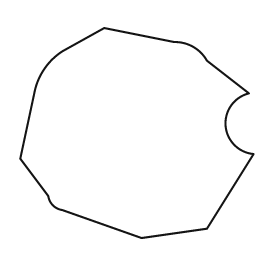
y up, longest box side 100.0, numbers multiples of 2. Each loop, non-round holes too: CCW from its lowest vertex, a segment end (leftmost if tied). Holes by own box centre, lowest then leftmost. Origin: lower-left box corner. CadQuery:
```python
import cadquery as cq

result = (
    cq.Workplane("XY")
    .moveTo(52.0, 0.0)
    .lineTo(80.0, 4.0)
    .lineTo(100.0, 36.0)
    .threePointArc((88.0, 48.0), (98.0, 62.0))
    .lineTo(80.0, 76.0)
    .threePointArc((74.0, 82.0), (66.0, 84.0))
    .lineTo(36.0, 90.0)
    .lineTo(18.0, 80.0)
    .threePointArc((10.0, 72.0), (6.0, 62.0))
    .lineTo(0.0, 34.0)
    .lineTo(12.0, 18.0)
    .threePointArc((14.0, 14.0), (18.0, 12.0))
    .close()
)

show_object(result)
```